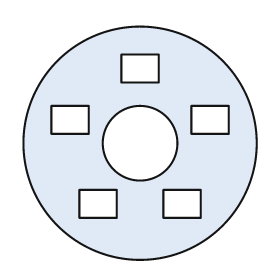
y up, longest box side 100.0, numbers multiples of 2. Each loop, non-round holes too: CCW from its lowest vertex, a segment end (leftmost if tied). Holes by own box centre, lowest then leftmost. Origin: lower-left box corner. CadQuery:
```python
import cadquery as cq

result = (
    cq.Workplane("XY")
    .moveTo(50.0, 50.0)
    .circle(50.0)
    .moveTo(24.0, 18.0)
    .lineTo(40.0, 18.0)
    .lineTo(40.0, 30.0)
    .lineTo(24.0, 30.0)
    .close()
    .moveTo(60.0, 18.0)
    .lineTo(76.0, 18.0)
    .lineTo(76.0, 30.0)
    .lineTo(60.0, 30.0)
    .close()
    .moveTo(50.0, 50.0)
    .circle(16.0)
    .moveTo(12.0, 54.0)
    .lineTo(28.0, 54.0)
    .lineTo(28.0, 66.0)
    .lineTo(12.0, 66.0)
    .close()
    .moveTo(72.0, 54.0)
    .lineTo(88.0, 54.0)
    .lineTo(88.0, 66.0)
    .lineTo(72.0, 66.0)
    .close()
    .moveTo(42.0, 76.0)
    .lineTo(58.0, 76.0)
    .lineTo(58.0, 88.0)
    .lineTo(42.0, 88.0)
    .close()
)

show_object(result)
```